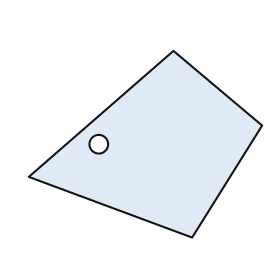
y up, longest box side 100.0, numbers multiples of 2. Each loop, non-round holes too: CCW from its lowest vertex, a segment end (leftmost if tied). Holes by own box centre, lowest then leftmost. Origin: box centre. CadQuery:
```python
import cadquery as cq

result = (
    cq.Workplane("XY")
    .moveTo(20.0, -40.0)
    .lineTo(50.0, 8.0)
    .lineTo(12.0, 40.0)
    .lineTo(-50.0, -14.0)
    .close()
    .moveTo(-20.0, 0.0)
    .circle(4.0)
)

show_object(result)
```